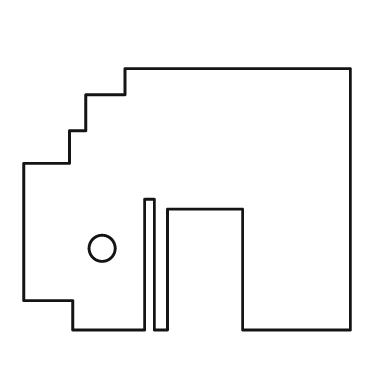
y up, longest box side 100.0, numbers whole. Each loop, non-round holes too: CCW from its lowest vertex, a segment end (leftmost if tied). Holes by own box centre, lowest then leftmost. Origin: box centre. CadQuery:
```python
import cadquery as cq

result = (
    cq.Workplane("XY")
    .moveTo(-35.0, -40.0)
    .lineTo(-13.0, -40.0)
    .lineTo(-13.0, 0.0)
    .lineTo(-10.0, 0.0)
    .lineTo(-10.0, -40.0)
    .lineTo(-6.0, -40.0)
    .lineTo(-6.0, -3.0)
    .lineTo(17.0, -3.0)
    .lineTo(17.0, -40.0)
    .lineTo(50.0, -40.0)
    .lineTo(50.0, 40.0)
    .lineTo(-19.0, 40.0)
    .lineTo(-19.0, 32.0)
    .lineTo(-31.0, 32.0)
    .lineTo(-31.0, 21.0)
    .lineTo(-36.0, 21.0)
    .lineTo(-36.0, 11.0)
    .lineTo(-50.0, 11.0)
    .lineTo(-50.0, -31.0)
    .lineTo(-35.0, -31.0)
    .close()
    .moveTo(-26.0, -15.0)
    .circle(4.0)
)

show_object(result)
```